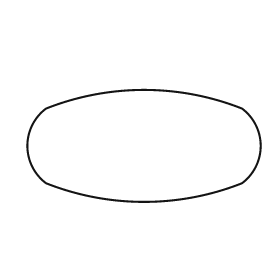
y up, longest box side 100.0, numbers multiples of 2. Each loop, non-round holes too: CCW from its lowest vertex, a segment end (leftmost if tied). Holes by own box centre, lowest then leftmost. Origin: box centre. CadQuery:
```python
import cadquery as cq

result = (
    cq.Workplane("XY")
    .moveTo(-42.0, -16.0)
    .threePointArc((0.0, -24.0), (42.0, -16.0))
    .threePointArc((50.0, 0.0), (42.0, 16.0))
    .threePointArc((0.0, 24.0), (-42.0, 16.0))
    .threePointArc((-50.0, 0.0), (-42.0, -16.0))
    .close()
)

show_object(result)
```